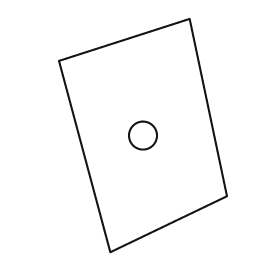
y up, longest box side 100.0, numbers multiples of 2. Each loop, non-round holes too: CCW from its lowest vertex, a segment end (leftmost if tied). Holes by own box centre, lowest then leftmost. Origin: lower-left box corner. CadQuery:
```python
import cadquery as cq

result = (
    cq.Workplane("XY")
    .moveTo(22.0, 0.0)
    .lineTo(72.0, 24.0)
    .lineTo(56.0, 100.0)
    .lineTo(0.0, 82.0)
    .close()
    .moveTo(36.0, 50.0)
    .circle(6.0)
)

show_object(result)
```